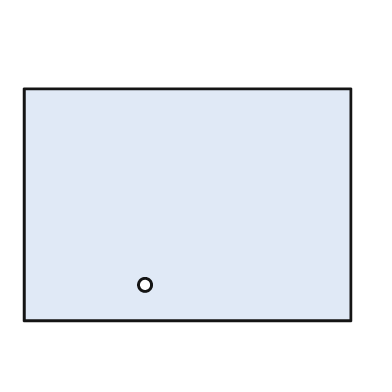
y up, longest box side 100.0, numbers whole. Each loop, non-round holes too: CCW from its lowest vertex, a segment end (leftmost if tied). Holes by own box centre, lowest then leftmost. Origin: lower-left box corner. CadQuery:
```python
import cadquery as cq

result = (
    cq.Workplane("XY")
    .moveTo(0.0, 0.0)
    .lineTo(100.0, 0.0)
    .lineTo(100.0, 71.0)
    .lineTo(0.0, 71.0)
    .close()
    .moveTo(37.0, 11.0)
    .circle(2.0)
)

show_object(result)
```